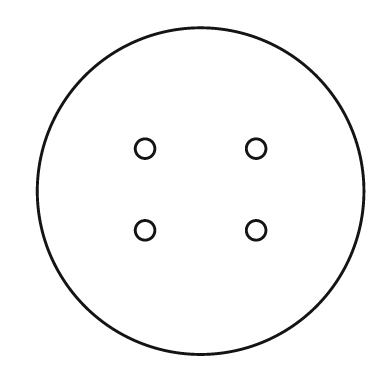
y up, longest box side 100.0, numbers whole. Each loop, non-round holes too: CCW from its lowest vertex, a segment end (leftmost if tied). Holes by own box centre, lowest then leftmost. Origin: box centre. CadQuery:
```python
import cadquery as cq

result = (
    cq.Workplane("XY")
    .moveTo(0.0, 0.0)
    .circle(50.0)
    .moveTo(-17.0, -12.0)
    .circle(3.0)
    .moveTo(17.0, -12.0)
    .circle(3.0)
    .moveTo(-17.0, 13.0)
    .circle(3.0)
    .moveTo(17.0, 13.0)
    .circle(3.0)
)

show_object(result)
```